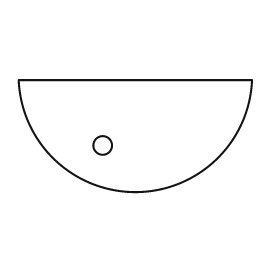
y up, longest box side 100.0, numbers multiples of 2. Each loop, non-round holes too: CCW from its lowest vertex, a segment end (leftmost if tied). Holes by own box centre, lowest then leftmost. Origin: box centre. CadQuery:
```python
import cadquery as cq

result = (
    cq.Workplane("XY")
    .moveTo(-50.0, 24.0)
    .threePointArc((0.0, -24.0), (50.0, 24.0))
    .close()
    .moveTo(-14.0, -4.0)
    .circle(4.0)
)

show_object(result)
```